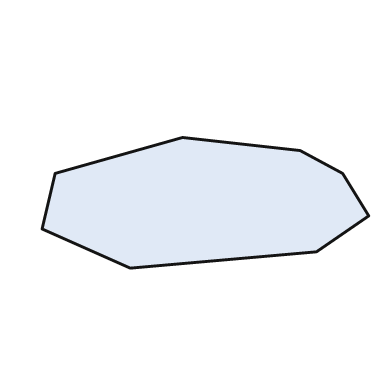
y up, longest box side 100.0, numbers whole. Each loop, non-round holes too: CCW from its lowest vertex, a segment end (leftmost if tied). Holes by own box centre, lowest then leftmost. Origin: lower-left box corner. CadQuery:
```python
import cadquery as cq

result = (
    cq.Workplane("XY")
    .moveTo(27.0, 0.0)
    .lineTo(84.0, 5.0)
    .lineTo(100.0, 16.0)
    .lineTo(92.0, 29.0)
    .lineTo(79.0, 36.0)
    .lineTo(43.0, 40.0)
    .lineTo(4.0, 29.0)
    .lineTo(0.0, 12.0)
    .close()
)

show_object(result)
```